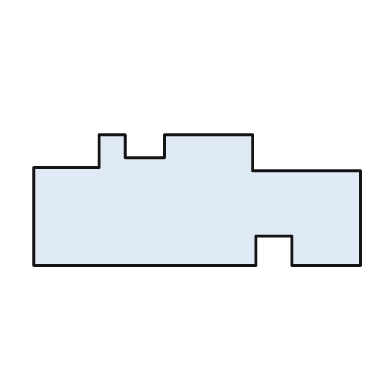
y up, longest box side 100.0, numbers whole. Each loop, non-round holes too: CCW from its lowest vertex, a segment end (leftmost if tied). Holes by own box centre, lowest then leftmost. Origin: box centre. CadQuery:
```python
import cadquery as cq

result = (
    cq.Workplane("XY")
    .moveTo(-50.0, -20.0)
    .lineTo(18.0, -20.0)
    .lineTo(18.0, -11.0)
    .lineTo(29.0, -11.0)
    .lineTo(29.0, -20.0)
    .lineTo(50.0, -20.0)
    .lineTo(50.0, 9.0)
    .lineTo(17.0, 9.0)
    .lineTo(17.0, 20.0)
    .lineTo(-10.0, 20.0)
    .lineTo(-10.0, 13.0)
    .lineTo(-22.0, 13.0)
    .lineTo(-22.0, 20.0)
    .lineTo(-30.0, 20.0)
    .lineTo(-30.0, 10.0)
    .lineTo(-50.0, 10.0)
    .close()
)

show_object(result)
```